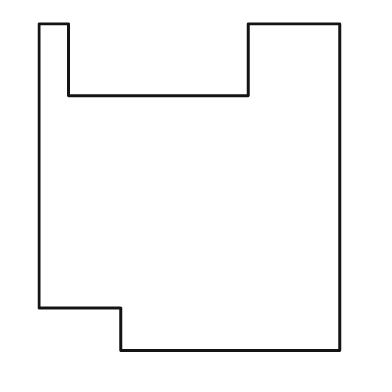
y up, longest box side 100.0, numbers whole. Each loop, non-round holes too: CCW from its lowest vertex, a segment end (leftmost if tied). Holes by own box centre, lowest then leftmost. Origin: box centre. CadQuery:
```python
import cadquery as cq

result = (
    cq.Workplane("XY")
    .moveTo(-21.0, -50.0)
    .lineTo(46.0, -50.0)
    .lineTo(46.0, 50.0)
    .lineTo(18.0, 50.0)
    .lineTo(18.0, 28.0)
    .lineTo(-37.0, 28.0)
    .lineTo(-37.0, 50.0)
    .lineTo(-46.0, 50.0)
    .lineTo(-46.0, -37.0)
    .lineTo(-21.0, -37.0)
    .close()
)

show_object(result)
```